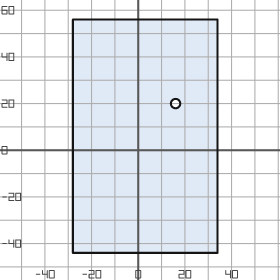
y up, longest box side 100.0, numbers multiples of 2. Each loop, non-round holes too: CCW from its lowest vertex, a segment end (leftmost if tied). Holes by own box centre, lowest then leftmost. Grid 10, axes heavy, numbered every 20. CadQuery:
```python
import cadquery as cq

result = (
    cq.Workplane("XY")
    .moveTo(-28.0, -44.0)
    .lineTo(34.0, -44.0)
    .lineTo(34.0, 56.0)
    .lineTo(-28.0, 56.0)
    .close()
    .moveTo(16.0, 20.0)
    .circle(2.0)
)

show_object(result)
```